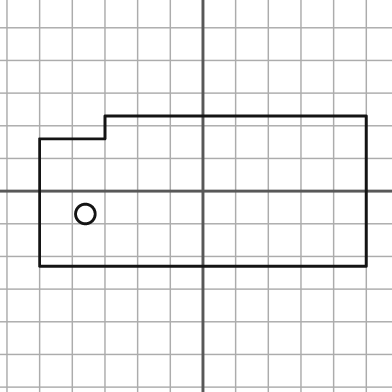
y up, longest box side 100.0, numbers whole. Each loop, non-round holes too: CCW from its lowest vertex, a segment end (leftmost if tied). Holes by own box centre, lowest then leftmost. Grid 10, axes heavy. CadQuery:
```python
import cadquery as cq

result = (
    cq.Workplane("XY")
    .moveTo(-50.0, -23.0)
    .lineTo(50.0, -23.0)
    .lineTo(50.0, 23.0)
    .lineTo(-30.0, 23.0)
    .lineTo(-30.0, 16.0)
    .lineTo(-50.0, 16.0)
    .close()
    .moveTo(-36.0, -7.0)
    .circle(3.0)
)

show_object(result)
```